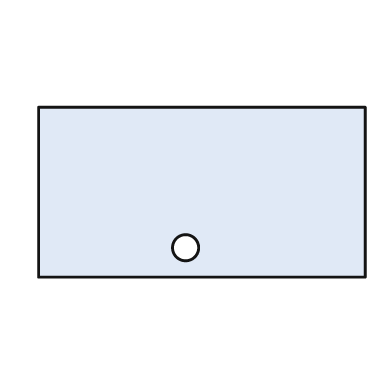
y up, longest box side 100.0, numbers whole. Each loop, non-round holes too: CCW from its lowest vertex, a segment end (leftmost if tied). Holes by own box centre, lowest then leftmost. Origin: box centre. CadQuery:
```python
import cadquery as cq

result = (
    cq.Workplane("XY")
    .moveTo(-50.0, -26.0)
    .lineTo(50.0, -26.0)
    .lineTo(50.0, 26.0)
    .lineTo(-50.0, 26.0)
    .close()
    .moveTo(-5.0, -17.0)
    .circle(4.0)
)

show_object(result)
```